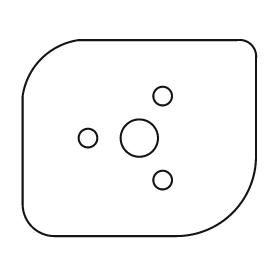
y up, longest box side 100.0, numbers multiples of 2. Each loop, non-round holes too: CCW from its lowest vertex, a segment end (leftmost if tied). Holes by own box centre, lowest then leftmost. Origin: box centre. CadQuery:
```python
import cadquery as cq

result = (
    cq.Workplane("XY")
    .moveTo(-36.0, -42.0)
    .lineTo(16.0, -42.0)
    .threePointArc((40.0, -32.0), (50.0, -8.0))
    .lineTo(50.0, 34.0)
    .threePointArc((48.0, 40.0), (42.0, 42.0))
    .lineTo(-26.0, 42.0)
    .threePointArc((-42.0, 34.0), (-50.0, 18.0))
    .lineTo(-50.0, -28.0)
    .threePointArc((-46.0, -38.0), (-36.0, -42.0))
    .close()
    .moveTo(10.0, -18.0)
    .circle(4.0)
    .moveTo(-22.0, 0.0)
    .circle(4.0)
    .moveTo(0.0, 0.0)
    .circle(8.0)
    .moveTo(10.0, 18.0)
    .circle(4.0)
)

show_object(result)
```